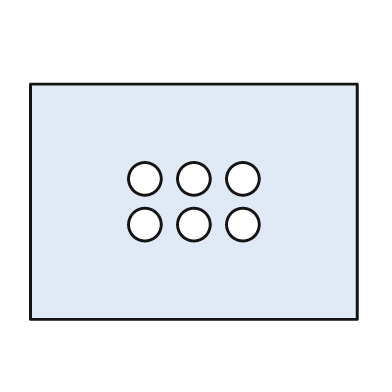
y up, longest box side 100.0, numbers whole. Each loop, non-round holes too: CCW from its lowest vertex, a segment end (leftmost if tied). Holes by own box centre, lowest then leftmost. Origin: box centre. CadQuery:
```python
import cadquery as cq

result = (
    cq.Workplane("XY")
    .moveTo(-50.0, -36.0)
    .lineTo(50.0, -36.0)
    .lineTo(50.0, 36.0)
    .lineTo(-50.0, 36.0)
    .close()
    .moveTo(-15.0, -7.0)
    .circle(5.0)
    .moveTo(0.0, -7.0)
    .circle(5.0)
    .moveTo(15.0, -7.0)
    .circle(5.0)
    .moveTo(-15.0, 7.0)
    .circle(5.0)
    .moveTo(0.0, 7.0)
    .circle(5.0)
    .moveTo(15.0, 7.0)
    .circle(5.0)
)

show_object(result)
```